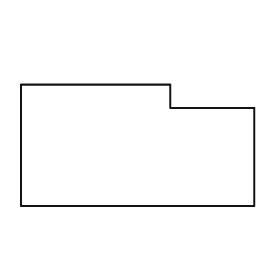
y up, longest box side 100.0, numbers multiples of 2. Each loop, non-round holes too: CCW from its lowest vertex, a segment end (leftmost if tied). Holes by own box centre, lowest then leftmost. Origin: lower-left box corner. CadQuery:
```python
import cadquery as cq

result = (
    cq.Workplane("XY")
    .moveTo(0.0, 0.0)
    .lineTo(100.0, 0.0)
    .lineTo(100.0, 42.0)
    .lineTo(64.0, 42.0)
    .lineTo(64.0, 52.0)
    .lineTo(0.0, 52.0)
    .close()
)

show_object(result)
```